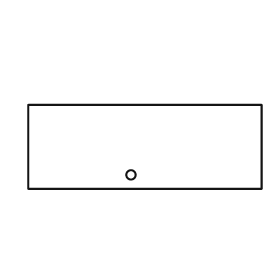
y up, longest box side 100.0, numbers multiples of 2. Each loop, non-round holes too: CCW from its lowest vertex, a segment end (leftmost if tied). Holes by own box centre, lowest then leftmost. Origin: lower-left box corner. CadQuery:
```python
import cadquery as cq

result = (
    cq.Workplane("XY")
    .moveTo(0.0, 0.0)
    .lineTo(100.0, 0.0)
    .lineTo(100.0, 36.0)
    .lineTo(0.0, 36.0)
    .close()
    .moveTo(44.0, 6.0)
    .circle(2.0)
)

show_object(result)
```